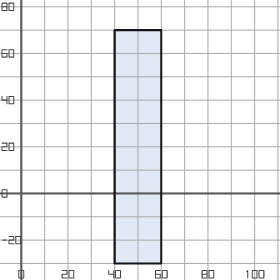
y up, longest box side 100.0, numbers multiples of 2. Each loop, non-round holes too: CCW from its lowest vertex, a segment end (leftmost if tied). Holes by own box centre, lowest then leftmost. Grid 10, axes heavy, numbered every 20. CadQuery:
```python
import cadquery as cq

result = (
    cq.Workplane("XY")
    .moveTo(40.0, -30.0)
    .lineTo(60.0, -30.0)
    .lineTo(60.0, 70.0)
    .lineTo(40.0, 70.0)
    .close()
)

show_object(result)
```